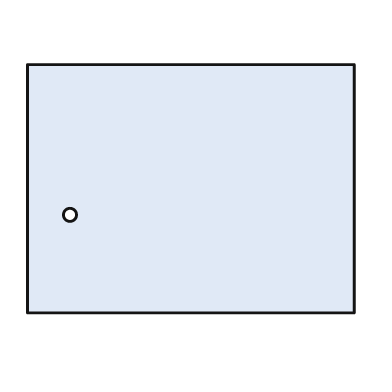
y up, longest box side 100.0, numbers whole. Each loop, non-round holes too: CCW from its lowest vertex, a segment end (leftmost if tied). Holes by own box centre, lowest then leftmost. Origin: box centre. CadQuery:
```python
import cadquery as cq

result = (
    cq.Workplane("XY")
    .moveTo(-50.0, -38.0)
    .lineTo(50.0, -38.0)
    .lineTo(50.0, 38.0)
    .lineTo(-50.0, 38.0)
    .close()
    .moveTo(-37.0, -8.0)
    .circle(2.0)
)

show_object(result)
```